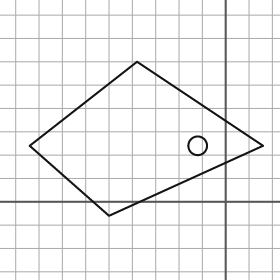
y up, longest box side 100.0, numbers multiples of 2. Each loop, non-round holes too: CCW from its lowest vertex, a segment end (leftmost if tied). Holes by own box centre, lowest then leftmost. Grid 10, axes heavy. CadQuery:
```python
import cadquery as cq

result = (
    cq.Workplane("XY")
    .moveTo(-50.0, -6.0)
    .lineTo(16.0, 24.0)
    .lineTo(-38.0, 60.0)
    .lineTo(-84.0, 24.0)
    .close()
    .moveTo(-12.0, 24.0)
    .circle(4.0)
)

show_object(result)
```